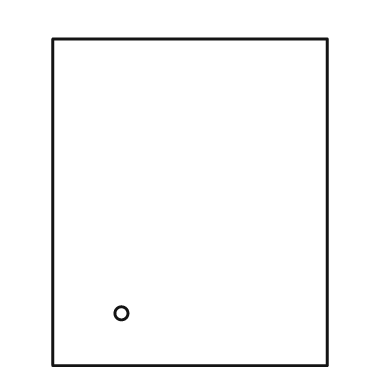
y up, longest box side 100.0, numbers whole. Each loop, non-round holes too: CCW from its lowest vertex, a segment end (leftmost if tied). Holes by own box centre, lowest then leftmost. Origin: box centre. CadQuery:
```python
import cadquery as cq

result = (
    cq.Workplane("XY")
    .moveTo(-42.0, -50.0)
    .lineTo(42.0, -50.0)
    .lineTo(42.0, 50.0)
    .lineTo(-42.0, 50.0)
    .close()
    .moveTo(-21.0, -34.0)
    .circle(2.0)
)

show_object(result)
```